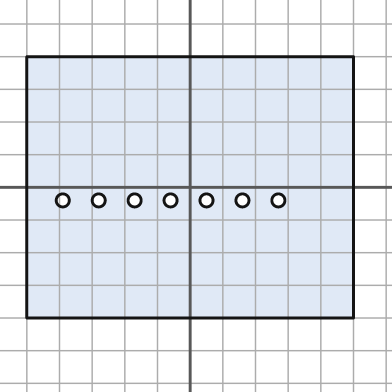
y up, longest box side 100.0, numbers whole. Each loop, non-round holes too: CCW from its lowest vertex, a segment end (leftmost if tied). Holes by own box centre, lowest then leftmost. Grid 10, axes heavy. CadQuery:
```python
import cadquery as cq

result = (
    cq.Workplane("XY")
    .moveTo(-50.0, -40.0)
    .lineTo(50.0, -40.0)
    .lineTo(50.0, 40.0)
    .lineTo(-50.0, 40.0)
    .close()
    .moveTo(-39.0, -4.0)
    .circle(2.0)
    .moveTo(-28.0, -4.0)
    .circle(2.0)
    .moveTo(-17.0, -4.0)
    .circle(2.0)
    .moveTo(-6.0, -4.0)
    .circle(2.0)
    .moveTo(5.0, -4.0)
    .circle(2.0)
    .moveTo(16.0, -4.0)
    .circle(2.0)
    .moveTo(27.0, -4.0)
    .circle(2.0)
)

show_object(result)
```